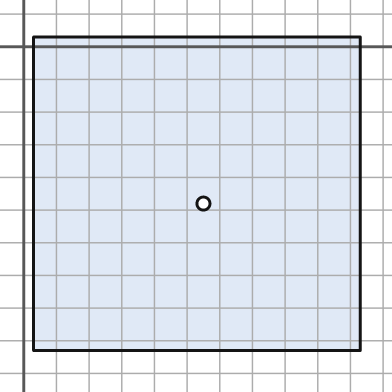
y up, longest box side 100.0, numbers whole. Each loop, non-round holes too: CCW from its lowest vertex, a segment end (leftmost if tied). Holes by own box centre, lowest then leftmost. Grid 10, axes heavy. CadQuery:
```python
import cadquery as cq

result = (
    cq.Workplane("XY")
    .moveTo(3.0, -93.0)
    .lineTo(103.0, -93.0)
    .lineTo(103.0, 3.0)
    .lineTo(3.0, 3.0)
    .close()
    .moveTo(55.0, -48.0)
    .circle(2.0)
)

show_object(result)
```